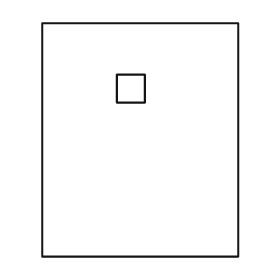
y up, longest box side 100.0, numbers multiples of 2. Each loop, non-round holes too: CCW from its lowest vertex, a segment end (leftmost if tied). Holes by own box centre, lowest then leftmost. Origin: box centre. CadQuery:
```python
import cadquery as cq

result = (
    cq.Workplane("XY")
    .moveTo(-42.0, -50.0)
    .lineTo(42.0, -50.0)
    .lineTo(42.0, 50.0)
    .lineTo(-42.0, 50.0)
    .close()
    .moveTo(-10.0, 16.0)
    .lineTo(2.0, 16.0)
    .lineTo(2.0, 28.0)
    .lineTo(-10.0, 28.0)
    .close()
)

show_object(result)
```